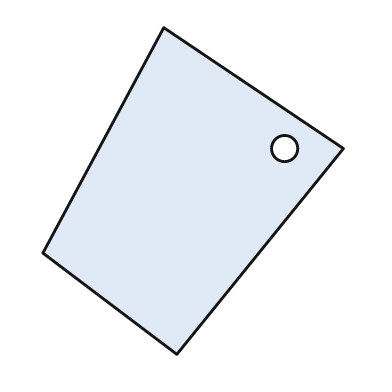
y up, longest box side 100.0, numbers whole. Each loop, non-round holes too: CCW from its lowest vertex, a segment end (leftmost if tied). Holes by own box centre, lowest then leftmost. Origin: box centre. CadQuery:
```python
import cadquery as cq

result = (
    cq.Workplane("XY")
    .moveTo(-5.0, -50.0)
    .lineTo(46.0, 13.0)
    .lineTo(-9.0, 50.0)
    .lineTo(-46.0, -19.0)
    .close()
    .moveTo(28.0, 13.0)
    .circle(4.0)
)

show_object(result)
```